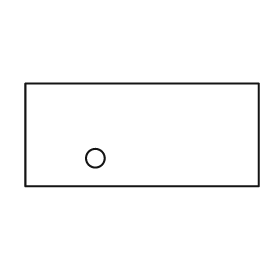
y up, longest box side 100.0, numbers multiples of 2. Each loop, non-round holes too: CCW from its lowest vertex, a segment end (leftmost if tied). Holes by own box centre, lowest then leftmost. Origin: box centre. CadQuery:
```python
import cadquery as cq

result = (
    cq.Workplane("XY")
    .moveTo(-50.0, -22.0)
    .lineTo(50.0, -22.0)
    .lineTo(50.0, 22.0)
    .lineTo(-50.0, 22.0)
    .close()
    .moveTo(-20.0, -10.0)
    .circle(4.0)
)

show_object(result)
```